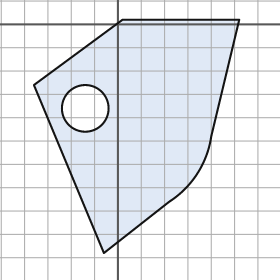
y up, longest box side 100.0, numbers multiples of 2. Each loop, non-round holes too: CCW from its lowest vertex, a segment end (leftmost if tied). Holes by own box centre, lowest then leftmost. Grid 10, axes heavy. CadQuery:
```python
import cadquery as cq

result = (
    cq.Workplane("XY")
    .moveTo(-6.0, -98.0)
    .lineTo(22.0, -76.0)
    .threePointArc((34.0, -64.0), (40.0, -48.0))
    .lineTo(52.0, 2.0)
    .lineTo(2.0, 2.0)
    .lineTo(-36.0, -26.0)
    .close()
    .moveTo(-14.0, -36.0)
    .circle(10.0)
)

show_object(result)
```